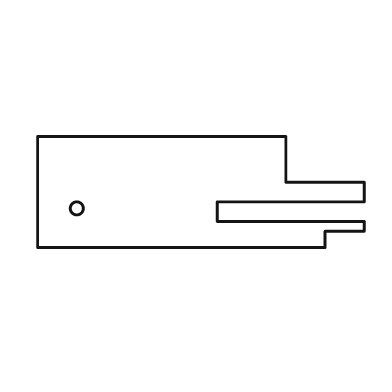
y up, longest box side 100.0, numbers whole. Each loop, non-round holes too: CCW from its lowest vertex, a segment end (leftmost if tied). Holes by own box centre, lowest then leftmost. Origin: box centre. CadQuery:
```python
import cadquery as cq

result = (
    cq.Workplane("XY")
    .moveTo(-50.0, -17.0)
    .lineTo(38.0, -17.0)
    .lineTo(38.0, -12.0)
    .lineTo(50.0, -12.0)
    .lineTo(50.0, -9.0)
    .lineTo(5.0, -9.0)
    .lineTo(5.0, -3.0)
    .lineTo(50.0, -3.0)
    .lineTo(50.0, 3.0)
    .lineTo(26.0, 3.0)
    .lineTo(26.0, 17.0)
    .lineTo(-50.0, 17.0)
    .close()
    .moveTo(-38.0, -5.0)
    .circle(2.0)
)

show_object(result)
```